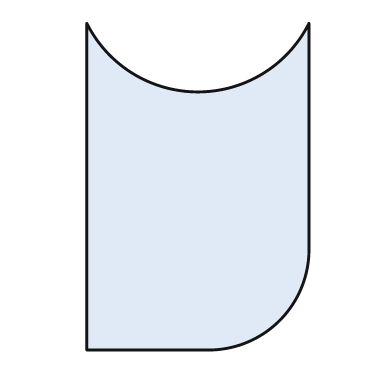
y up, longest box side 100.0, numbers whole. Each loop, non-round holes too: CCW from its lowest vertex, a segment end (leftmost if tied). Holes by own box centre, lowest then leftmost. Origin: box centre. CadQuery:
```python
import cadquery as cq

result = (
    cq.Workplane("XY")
    .moveTo(-34.0, -50.0)
    .lineTo(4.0, -50.0)
    .threePointArc((25.0, -41.0), (34.0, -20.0))
    .lineTo(34.0, 50.0)
    .threePointArc((0.0, 29.0), (-34.0, 50.0))
    .close()
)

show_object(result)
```